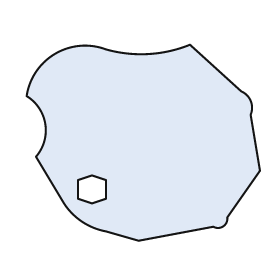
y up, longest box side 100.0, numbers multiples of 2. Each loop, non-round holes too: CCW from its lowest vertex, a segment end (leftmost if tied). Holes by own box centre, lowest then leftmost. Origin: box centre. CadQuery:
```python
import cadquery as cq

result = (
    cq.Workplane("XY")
    .moveTo(-2.0, -42.0)
    .lineTo(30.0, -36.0)
    .threePointArc((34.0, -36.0), (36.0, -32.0))
    .lineTo(50.0, -12.0)
    .lineTo(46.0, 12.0)
    .threePointArc((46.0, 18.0), (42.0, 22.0))
    .lineTo(20.0, 42.0)
    .threePointArc((2.0, 38.0), (-16.0, 40.0))
    .threePointArc((-38.0, 38.0), (-50.0, 20.0))
    .threePointArc((-42.0, 8.0), (-46.0, -6.0))
    .lineTo(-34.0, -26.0)
    .threePointArc((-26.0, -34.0), (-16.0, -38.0))
    .close()
    .moveTo(-22.0, -26.0)
    .lineTo(-16.0, -24.0)
    .lineTo(-16.0, -16.0)
    .lineTo(-22.0, -14.0)
    .lineTo(-28.0, -16.0)
    .lineTo(-28.0, -24.0)
    .close()
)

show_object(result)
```